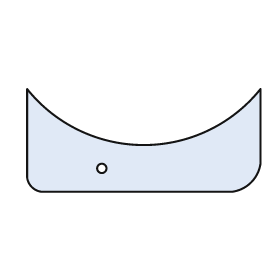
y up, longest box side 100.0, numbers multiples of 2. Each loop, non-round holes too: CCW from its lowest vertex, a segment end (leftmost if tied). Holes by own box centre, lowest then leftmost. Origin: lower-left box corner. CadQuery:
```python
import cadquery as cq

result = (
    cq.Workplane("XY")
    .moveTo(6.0, 0.0)
    .lineTo(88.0, 0.0)
    .threePointArc((96.0, 4.0), (100.0, 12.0))
    .lineTo(100.0, 44.0)
    .threePointArc((50.0, 20.0), (0.0, 44.0))
    .lineTo(0.0, 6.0)
    .threePointArc((2.0, 2.0), (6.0, 0.0))
    .close()
    .moveTo(32.0, 10.0)
    .circle(2.0)
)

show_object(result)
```